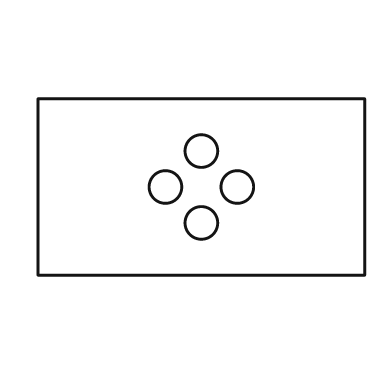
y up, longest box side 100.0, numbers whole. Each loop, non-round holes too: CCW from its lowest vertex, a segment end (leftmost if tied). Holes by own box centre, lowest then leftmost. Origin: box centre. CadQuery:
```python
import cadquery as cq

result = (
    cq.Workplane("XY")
    .moveTo(-50.0, -27.0)
    .lineTo(50.0, -27.0)
    .lineTo(50.0, 27.0)
    .lineTo(-50.0, 27.0)
    .close()
    .moveTo(0.0, -11.0)
    .circle(5.0)
    .moveTo(-11.0, 0.0)
    .circle(5.0)
    .moveTo(11.0, 0.0)
    .circle(5.0)
    .moveTo(0.0, 11.0)
    .circle(5.0)
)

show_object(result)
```